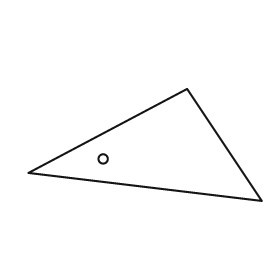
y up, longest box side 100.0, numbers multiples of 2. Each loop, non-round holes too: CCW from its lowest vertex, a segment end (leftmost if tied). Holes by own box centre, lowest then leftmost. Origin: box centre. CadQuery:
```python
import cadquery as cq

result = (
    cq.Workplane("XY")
    .moveTo(50.0, -24.0)
    .lineTo(18.0, 24.0)
    .lineTo(-50.0, -12.0)
    .close()
    .moveTo(-18.0, -6.0)
    .circle(2.0)
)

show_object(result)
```